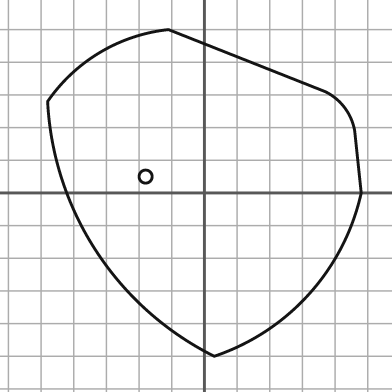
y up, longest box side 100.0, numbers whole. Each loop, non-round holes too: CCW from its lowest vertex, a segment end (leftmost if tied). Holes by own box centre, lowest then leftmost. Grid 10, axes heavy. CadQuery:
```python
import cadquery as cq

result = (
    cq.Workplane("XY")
    .moveTo(3.0, -50.0)
    .threePointArc((32.0, -31.0), (48.0, 0.0))
    .lineTo(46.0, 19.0)
    .threePointArc((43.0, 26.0), (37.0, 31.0))
    .lineTo(-11.0, 50.0)
    .threePointArc((-32.0, 43.0), (-48.0, 28.0))
    .threePointArc((-33.0, -18.0), (3.0, -50.0))
    .close()
    .moveTo(-18.0, 5.0)
    .circle(2.0)
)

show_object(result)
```